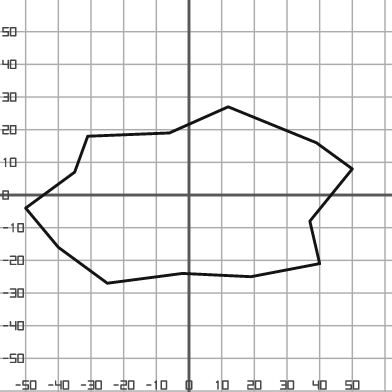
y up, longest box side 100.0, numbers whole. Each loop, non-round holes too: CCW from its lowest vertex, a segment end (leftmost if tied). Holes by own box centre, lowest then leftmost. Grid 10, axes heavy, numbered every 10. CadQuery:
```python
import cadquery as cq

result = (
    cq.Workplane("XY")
    .moveTo(-25.0, -27.0)
    .lineTo(-2.0, -24.0)
    .lineTo(19.0, -25.0)
    .lineTo(40.0, -21.0)
    .lineTo(37.0, -8.0)
    .lineTo(50.0, 8.0)
    .lineTo(39.0, 16.0)
    .lineTo(12.0, 27.0)
    .lineTo(-6.0, 19.0)
    .lineTo(-31.0, 18.0)
    .lineTo(-35.0, 7.0)
    .lineTo(-50.0, -4.0)
    .lineTo(-40.0, -16.0)
    .close()
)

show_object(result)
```